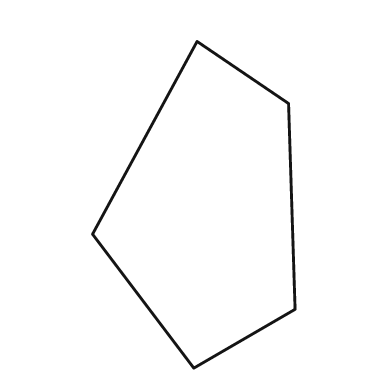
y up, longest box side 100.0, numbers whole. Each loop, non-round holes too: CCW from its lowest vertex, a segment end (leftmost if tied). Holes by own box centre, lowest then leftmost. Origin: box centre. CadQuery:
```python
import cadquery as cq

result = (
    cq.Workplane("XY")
    .moveTo(0.0, -50.0)
    .lineTo(31.0, -32.0)
    .lineTo(29.0, 31.0)
    .lineTo(1.0, 50.0)
    .lineTo(-31.0, -9.0)
    .close()
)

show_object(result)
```